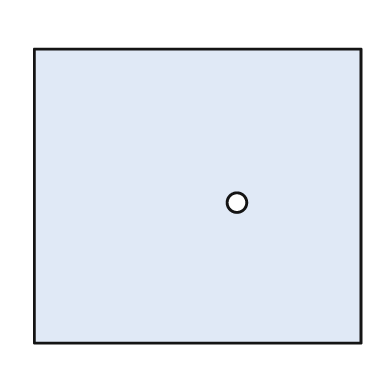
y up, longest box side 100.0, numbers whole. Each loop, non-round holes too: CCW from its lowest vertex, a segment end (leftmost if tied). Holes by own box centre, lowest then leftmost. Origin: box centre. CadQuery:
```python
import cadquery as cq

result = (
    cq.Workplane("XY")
    .moveTo(-50.0, -45.0)
    .lineTo(50.0, -45.0)
    .lineTo(50.0, 45.0)
    .lineTo(-50.0, 45.0)
    .close()
    .moveTo(12.0, -2.0)
    .circle(3.0)
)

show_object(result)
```